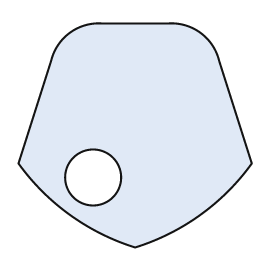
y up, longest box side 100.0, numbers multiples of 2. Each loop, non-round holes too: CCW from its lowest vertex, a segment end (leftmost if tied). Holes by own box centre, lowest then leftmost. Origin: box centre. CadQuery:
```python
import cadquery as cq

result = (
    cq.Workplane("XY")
    .moveTo(0.0, -48.0)
    .threePointArc((28.0, -34.0), (50.0, -12.0))
    .lineTo(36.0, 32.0)
    .threePointArc((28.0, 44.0), (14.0, 48.0))
    .lineTo(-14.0, 48.0)
    .threePointArc((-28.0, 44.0), (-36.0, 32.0))
    .lineTo(-50.0, -12.0)
    .threePointArc((-28.0, -34.0), (0.0, -48.0))
    .close()
    .moveTo(-18.0, -18.0)
    .circle(12.0)
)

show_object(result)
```